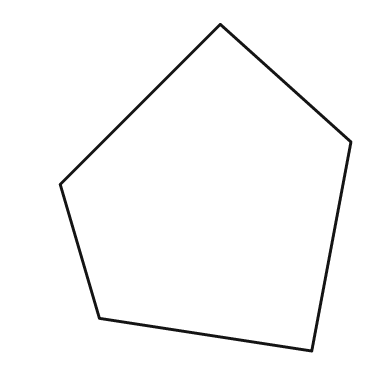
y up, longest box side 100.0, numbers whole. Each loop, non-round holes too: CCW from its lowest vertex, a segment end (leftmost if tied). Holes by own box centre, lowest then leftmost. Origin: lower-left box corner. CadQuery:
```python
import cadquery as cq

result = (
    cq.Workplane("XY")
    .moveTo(77.0, 0.0)
    .lineTo(89.0, 64.0)
    .lineTo(49.0, 100.0)
    .lineTo(0.0, 51.0)
    .lineTo(12.0, 10.0)
    .close()
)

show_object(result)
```